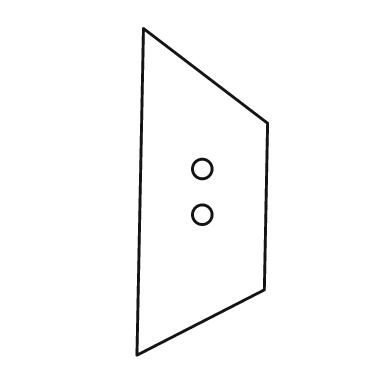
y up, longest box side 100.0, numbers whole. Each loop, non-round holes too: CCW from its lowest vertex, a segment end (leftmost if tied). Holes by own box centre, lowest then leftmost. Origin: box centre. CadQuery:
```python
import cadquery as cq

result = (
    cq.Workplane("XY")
    .moveTo(-20.0, -50.0)
    .lineTo(19.0, -30.0)
    .lineTo(20.0, 21.0)
    .lineTo(-18.0, 50.0)
    .close()
    .moveTo(0.0, -7.0)
    .circle(3.0)
    .moveTo(0.0, 7.0)
    .circle(3.0)
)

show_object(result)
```